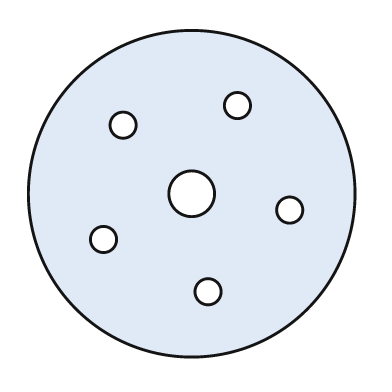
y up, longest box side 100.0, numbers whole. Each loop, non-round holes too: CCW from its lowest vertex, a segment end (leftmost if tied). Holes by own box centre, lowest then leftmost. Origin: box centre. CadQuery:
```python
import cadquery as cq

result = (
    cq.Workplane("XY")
    .moveTo(0.0, 0.0)
    .circle(50.0)
    .moveTo(5.0, -30.0)
    .circle(4.0)
    .moveTo(-27.0, -14.0)
    .circle(4.0)
    .moveTo(30.0, -5.0)
    .circle(4.0)
    .moveTo(0.0, 0.0)
    .circle(7.0)
    .moveTo(-21.0, 21.0)
    .circle(4.0)
    .moveTo(14.0, 27.0)
    .circle(4.0)
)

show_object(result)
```